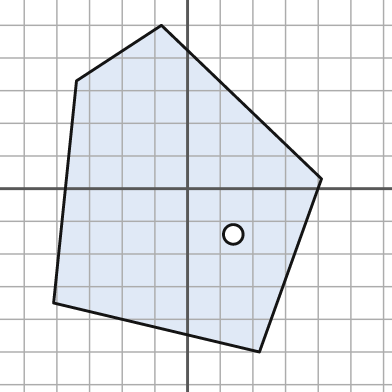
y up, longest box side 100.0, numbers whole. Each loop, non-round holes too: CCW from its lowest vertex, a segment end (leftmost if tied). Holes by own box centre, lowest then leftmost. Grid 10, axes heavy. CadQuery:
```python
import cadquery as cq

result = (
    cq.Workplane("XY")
    .moveTo(22.0, -50.0)
    .lineTo(41.0, 3.0)
    .lineTo(-8.0, 50.0)
    .lineTo(-34.0, 33.0)
    .lineTo(-41.0, -35.0)
    .close()
    .moveTo(14.0, -14.0)
    .circle(3.0)
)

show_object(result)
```